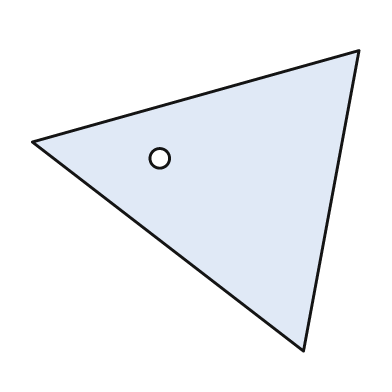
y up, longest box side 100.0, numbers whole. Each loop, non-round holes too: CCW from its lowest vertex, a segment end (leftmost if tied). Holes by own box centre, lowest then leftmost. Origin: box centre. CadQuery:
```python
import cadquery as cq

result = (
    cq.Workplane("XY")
    .moveTo(33.0, -46.0)
    .lineTo(50.0, 46.0)
    .lineTo(-50.0, 18.0)
    .close()
    .moveTo(-11.0, 13.0)
    .circle(3.0)
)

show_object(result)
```